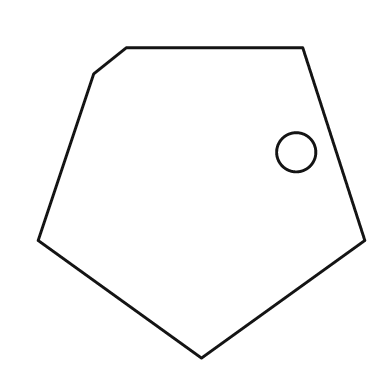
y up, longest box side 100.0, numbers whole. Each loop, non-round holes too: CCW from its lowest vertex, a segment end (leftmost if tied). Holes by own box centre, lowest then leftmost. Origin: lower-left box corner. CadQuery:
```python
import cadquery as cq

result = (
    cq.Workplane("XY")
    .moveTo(50.0, 0.0)
    .lineTo(100.0, 36.0)
    .lineTo(81.0, 95.0)
    .lineTo(27.0, 95.0)
    .lineTo(17.0, 87.0)
    .lineTo(0.0, 36.0)
    .close()
    .moveTo(79.0, 63.0)
    .circle(6.0)
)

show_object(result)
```